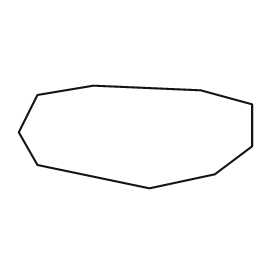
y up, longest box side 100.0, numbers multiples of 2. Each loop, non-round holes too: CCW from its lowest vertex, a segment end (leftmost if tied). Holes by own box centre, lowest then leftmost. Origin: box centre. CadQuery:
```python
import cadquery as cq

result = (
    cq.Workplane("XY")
    .moveTo(6.0, -22.0)
    .lineTo(34.0, -16.0)
    .lineTo(50.0, -4.0)
    .lineTo(50.0, 14.0)
    .lineTo(28.0, 20.0)
    .lineTo(-18.0, 22.0)
    .lineTo(-42.0, 18.0)
    .lineTo(-50.0, 2.0)
    .lineTo(-42.0, -12.0)
    .close()
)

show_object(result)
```